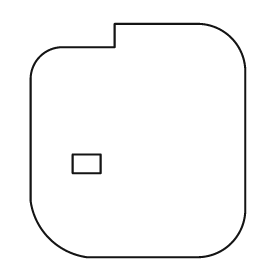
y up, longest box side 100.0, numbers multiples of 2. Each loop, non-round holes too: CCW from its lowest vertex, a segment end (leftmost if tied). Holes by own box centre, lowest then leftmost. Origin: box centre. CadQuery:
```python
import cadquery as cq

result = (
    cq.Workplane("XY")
    .moveTo(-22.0, -50.0)
    .lineTo(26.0, -50.0)
    .threePointArc((40.0, -44.0), (46.0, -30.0))
    .lineTo(46.0, 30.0)
    .threePointArc((40.0, 44.0), (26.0, 50.0))
    .lineTo(-10.0, 50.0)
    .lineTo(-10.0, 40.0)
    .lineTo(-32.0, 40.0)
    .threePointArc((-42.0, 36.0), (-46.0, 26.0))
    .lineTo(-46.0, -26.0)
    .threePointArc((-38.0, -42.0), (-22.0, -50.0))
    .close()
    .moveTo(-28.0, -14.0)
    .lineTo(-16.0, -14.0)
    .lineTo(-16.0, -6.0)
    .lineTo(-28.0, -6.0)
    .close()
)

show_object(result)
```